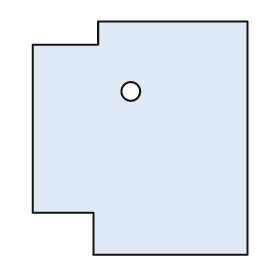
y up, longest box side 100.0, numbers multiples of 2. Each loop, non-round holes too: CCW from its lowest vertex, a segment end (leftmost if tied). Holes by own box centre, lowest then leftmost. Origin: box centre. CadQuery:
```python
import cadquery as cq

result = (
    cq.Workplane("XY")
    .moveTo(-20.0, -50.0)
    .lineTo(46.0, -50.0)
    .lineTo(46.0, 50.0)
    .lineTo(-18.0, 50.0)
    .lineTo(-18.0, 40.0)
    .lineTo(-46.0, 40.0)
    .lineTo(-46.0, -32.0)
    .lineTo(-20.0, -32.0)
    .close()
    .moveTo(-4.0, 20.0)
    .circle(4.0)
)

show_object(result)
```